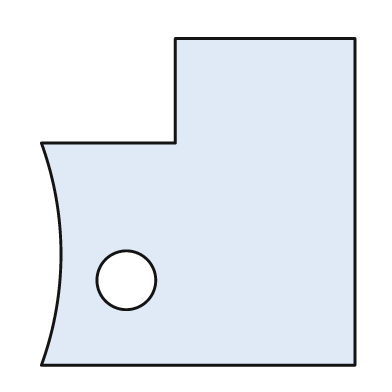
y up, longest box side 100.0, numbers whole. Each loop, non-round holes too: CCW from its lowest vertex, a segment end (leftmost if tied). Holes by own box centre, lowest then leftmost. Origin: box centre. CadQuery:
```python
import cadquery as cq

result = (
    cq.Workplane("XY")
    .moveTo(-48.0, -50.0)
    .lineTo(48.0, -50.0)
    .lineTo(48.0, 50.0)
    .lineTo(-7.0, 50.0)
    .lineTo(-7.0, 18.0)
    .lineTo(-48.0, 18.0)
    .threePointArc((-42.0, -16.0), (-48.0, -50.0))
    .close()
    .moveTo(-22.0, -24.0)
    .circle(9.0)
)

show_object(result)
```